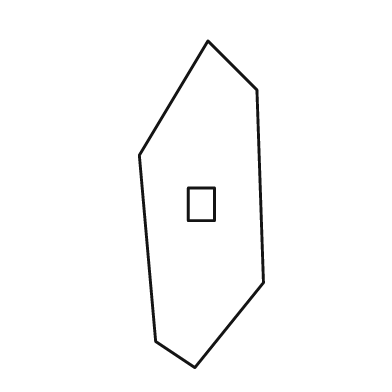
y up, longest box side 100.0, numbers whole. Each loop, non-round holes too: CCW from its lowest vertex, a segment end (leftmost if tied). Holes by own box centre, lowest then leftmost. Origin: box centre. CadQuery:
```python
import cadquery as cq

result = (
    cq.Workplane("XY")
    .moveTo(-2.0, -50.0)
    .lineTo(19.0, -24.0)
    .lineTo(17.0, 35.0)
    .lineTo(2.0, 50.0)
    .lineTo(-19.0, 15.0)
    .lineTo(-14.0, -42.0)
    .close()
    .moveTo(-4.0, -5.0)
    .lineTo(4.0, -5.0)
    .lineTo(4.0, 5.0)
    .lineTo(-4.0, 5.0)
    .close()
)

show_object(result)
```